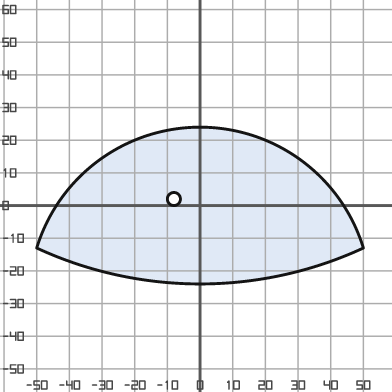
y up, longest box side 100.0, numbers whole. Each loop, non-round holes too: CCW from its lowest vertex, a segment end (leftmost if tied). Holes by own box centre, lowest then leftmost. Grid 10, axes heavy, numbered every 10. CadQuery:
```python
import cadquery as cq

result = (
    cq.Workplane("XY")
    .moveTo(-50.0, -13.0)
    .threePointArc((0.0, -24.0), (50.0, -13.0))
    .threePointArc((0.0, 24.0), (-50.0, -13.0))
    .close()
    .moveTo(-8.0, 2.0)
    .circle(2.0)
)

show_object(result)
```